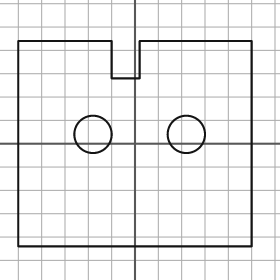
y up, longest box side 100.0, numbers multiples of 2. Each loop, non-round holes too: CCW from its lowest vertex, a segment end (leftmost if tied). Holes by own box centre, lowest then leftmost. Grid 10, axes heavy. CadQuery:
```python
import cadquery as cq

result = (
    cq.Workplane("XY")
    .moveTo(-50.0, -44.0)
    .lineTo(50.0, -44.0)
    .lineTo(50.0, 44.0)
    .lineTo(2.0, 44.0)
    .lineTo(2.0, 28.0)
    .lineTo(-10.0, 28.0)
    .lineTo(-10.0, 44.0)
    .lineTo(-50.0, 44.0)
    .close()
    .moveTo(-18.0, 4.0)
    .circle(8.0)
    .moveTo(22.0, 4.0)
    .circle(8.0)
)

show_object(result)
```